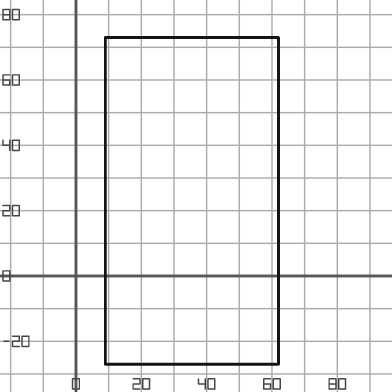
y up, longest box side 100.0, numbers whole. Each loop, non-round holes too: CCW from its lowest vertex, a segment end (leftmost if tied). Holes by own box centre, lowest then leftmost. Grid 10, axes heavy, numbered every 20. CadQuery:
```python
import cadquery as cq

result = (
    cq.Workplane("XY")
    .moveTo(9.0, -27.0)
    .lineTo(62.0, -27.0)
    .lineTo(62.0, 73.0)
    .lineTo(9.0, 73.0)
    .close()
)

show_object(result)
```